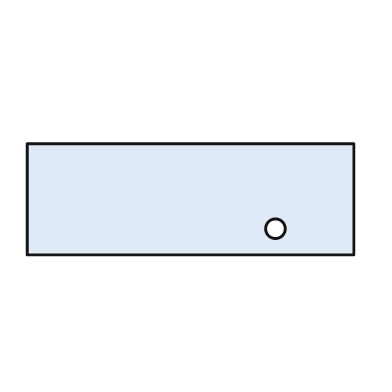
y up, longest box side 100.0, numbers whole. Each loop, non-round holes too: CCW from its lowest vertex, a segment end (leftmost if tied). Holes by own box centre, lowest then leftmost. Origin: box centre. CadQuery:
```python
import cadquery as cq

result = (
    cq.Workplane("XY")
    .moveTo(-50.0, -17.0)
    .lineTo(50.0, -17.0)
    .lineTo(50.0, 17.0)
    .lineTo(-50.0, 17.0)
    .close()
    .moveTo(26.0, -9.0)
    .circle(3.0)
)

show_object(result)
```